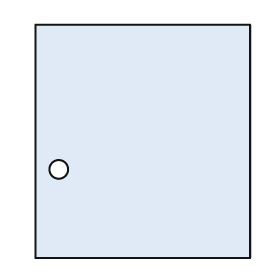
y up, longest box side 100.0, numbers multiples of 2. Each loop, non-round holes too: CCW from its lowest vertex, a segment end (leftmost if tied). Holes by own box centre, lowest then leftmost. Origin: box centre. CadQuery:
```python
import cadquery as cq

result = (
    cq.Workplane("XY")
    .moveTo(-46.0, -50.0)
    .lineTo(46.0, -50.0)
    .lineTo(46.0, 50.0)
    .lineTo(-46.0, 50.0)
    .close()
    .moveTo(-36.0, -12.0)
    .circle(4.0)
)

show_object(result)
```